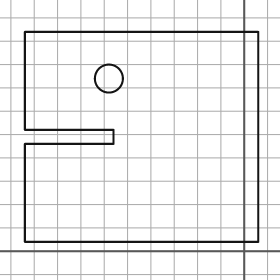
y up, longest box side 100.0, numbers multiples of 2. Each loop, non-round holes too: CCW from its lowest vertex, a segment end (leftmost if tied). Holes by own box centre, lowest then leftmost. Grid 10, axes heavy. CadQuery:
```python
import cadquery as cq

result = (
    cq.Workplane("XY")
    .moveTo(-94.0, 4.0)
    .lineTo(6.0, 4.0)
    .lineTo(6.0, 94.0)
    .lineTo(-94.0, 94.0)
    .lineTo(-94.0, 52.0)
    .lineTo(-56.0, 52.0)
    .lineTo(-56.0, 46.0)
    .lineTo(-94.0, 46.0)
    .close()
    .moveTo(-58.0, 74.0)
    .circle(6.0)
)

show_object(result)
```